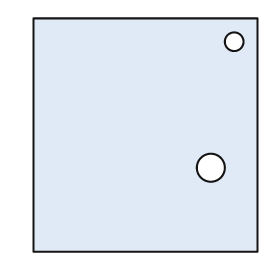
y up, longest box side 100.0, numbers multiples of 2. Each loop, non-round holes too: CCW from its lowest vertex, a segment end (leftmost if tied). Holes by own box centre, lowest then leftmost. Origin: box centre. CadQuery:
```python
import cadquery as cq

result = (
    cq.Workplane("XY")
    .moveTo(-48.0, -50.0)
    .lineTo(48.0, -50.0)
    .lineTo(48.0, 50.0)
    .lineTo(-48.0, 50.0)
    .close()
    .moveTo(28.0, -14.0)
    .circle(6.0)
    .moveTo(38.0, 40.0)
    .circle(4.0)
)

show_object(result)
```